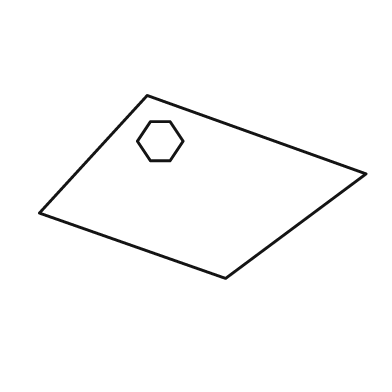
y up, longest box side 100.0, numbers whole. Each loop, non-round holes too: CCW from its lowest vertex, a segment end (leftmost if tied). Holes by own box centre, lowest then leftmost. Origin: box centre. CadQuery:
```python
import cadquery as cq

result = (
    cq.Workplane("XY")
    .moveTo(7.0, -28.0)
    .lineTo(50.0, 4.0)
    .lineTo(-17.0, 28.0)
    .lineTo(-50.0, -8.0)
    .close()
    .moveTo(-16.0, 8.0)
    .lineTo(-10.0, 8.0)
    .lineTo(-6.0, 14.0)
    .lineTo(-10.0, 20.0)
    .lineTo(-16.0, 20.0)
    .lineTo(-20.0, 14.0)
    .close()
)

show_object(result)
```